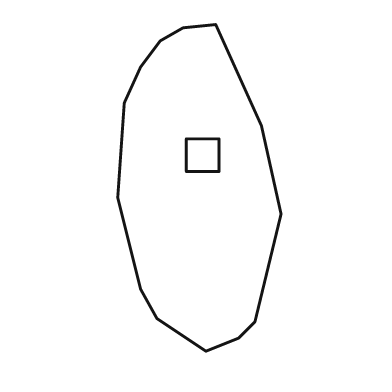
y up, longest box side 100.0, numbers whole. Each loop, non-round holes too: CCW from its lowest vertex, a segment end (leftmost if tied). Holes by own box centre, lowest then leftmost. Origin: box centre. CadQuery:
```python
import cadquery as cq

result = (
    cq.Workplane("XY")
    .moveTo(2.0, -50.0)
    .lineTo(12.0, -46.0)
    .lineTo(17.0, -41.0)
    .lineTo(25.0, -8.0)
    .lineTo(19.0, 19.0)
    .lineTo(5.0, 50.0)
    .lineTo(-5.0, 49.0)
    .lineTo(-12.0, 45.0)
    .lineTo(-18.0, 37.0)
    .lineTo(-23.0, 26.0)
    .lineTo(-25.0, -3.0)
    .lineTo(-18.0, -31.0)
    .lineTo(-13.0, -40.0)
    .close()
    .moveTo(-4.0, 5.0)
    .lineTo(6.0, 5.0)
    .lineTo(6.0, 15.0)
    .lineTo(-4.0, 15.0)
    .close()
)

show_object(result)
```